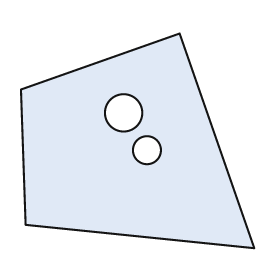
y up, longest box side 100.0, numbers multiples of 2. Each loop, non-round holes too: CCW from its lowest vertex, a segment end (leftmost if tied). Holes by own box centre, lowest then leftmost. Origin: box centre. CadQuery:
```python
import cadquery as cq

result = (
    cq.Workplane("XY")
    .moveTo(50.0, -46.0)
    .lineTo(18.0, 46.0)
    .lineTo(-50.0, 22.0)
    .lineTo(-48.0, -36.0)
    .close()
    .moveTo(4.0, -4.0)
    .circle(6.0)
    .moveTo(-6.0, 12.0)
    .circle(8.0)
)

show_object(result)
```